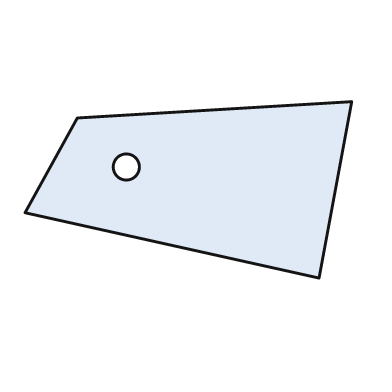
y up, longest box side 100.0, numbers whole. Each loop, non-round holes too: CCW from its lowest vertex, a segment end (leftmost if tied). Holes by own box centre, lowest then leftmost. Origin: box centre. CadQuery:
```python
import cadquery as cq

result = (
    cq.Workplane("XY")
    .moveTo(40.0, -27.0)
    .lineTo(50.0, 27.0)
    .lineTo(-34.0, 22.0)
    .lineTo(-50.0, -7.0)
    .close()
    .moveTo(-19.0, 7.0)
    .circle(4.0)
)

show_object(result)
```